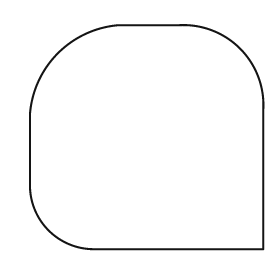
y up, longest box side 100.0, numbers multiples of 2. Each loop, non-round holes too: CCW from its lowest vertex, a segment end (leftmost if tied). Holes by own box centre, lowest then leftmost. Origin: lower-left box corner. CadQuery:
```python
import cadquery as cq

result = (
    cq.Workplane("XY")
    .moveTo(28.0, 0.0)
    .lineTo(100.0, 0.0)
    .lineTo(100.0, 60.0)
    .threePointArc((90.0, 86.0), (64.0, 96.0))
    .lineTo(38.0, 96.0)
    .threePointArc((12.0, 84.0), (0.0, 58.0))
    .lineTo(0.0, 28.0)
    .threePointArc((8.0, 8.0), (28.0, 0.0))
    .close()
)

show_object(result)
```